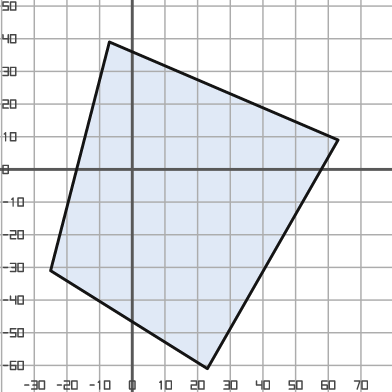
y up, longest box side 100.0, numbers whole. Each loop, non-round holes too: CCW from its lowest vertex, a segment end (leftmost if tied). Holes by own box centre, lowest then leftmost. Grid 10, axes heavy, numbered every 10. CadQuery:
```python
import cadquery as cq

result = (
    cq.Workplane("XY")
    .moveTo(23.0, -61.0)
    .lineTo(63.0, 9.0)
    .lineTo(-7.0, 39.0)
    .lineTo(-25.0, -31.0)
    .close()
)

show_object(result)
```